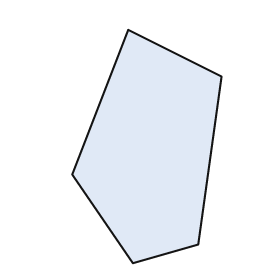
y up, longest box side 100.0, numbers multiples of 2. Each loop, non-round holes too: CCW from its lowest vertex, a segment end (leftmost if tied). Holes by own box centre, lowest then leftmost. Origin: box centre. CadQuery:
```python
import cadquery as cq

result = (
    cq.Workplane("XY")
    .moveTo(-6.0, -50.0)
    .lineTo(22.0, -42.0)
    .lineTo(32.0, 30.0)
    .lineTo(-8.0, 50.0)
    .lineTo(-32.0, -12.0)
    .close()
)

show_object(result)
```